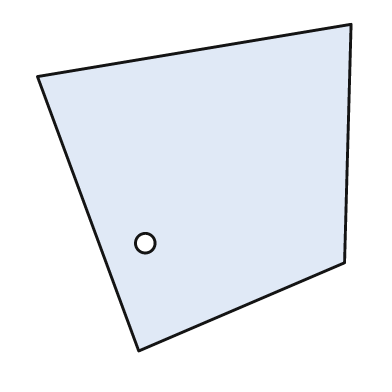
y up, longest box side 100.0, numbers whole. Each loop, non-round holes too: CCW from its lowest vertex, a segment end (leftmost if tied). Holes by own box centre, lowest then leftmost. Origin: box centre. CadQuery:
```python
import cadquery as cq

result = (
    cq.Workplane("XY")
    .moveTo(-17.0, -50.0)
    .lineTo(46.0, -23.0)
    .lineTo(48.0, 50.0)
    .lineTo(-48.0, 34.0)
    .close()
    .moveTo(-15.0, -17.0)
    .circle(3.0)
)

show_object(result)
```